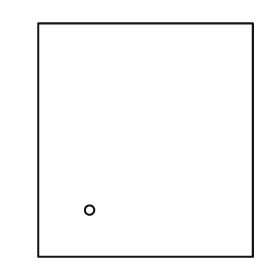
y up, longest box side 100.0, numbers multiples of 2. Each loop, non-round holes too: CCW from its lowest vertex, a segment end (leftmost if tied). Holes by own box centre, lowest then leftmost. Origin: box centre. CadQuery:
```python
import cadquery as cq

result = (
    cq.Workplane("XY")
    .moveTo(-46.0, -50.0)
    .lineTo(46.0, -50.0)
    .lineTo(46.0, 50.0)
    .lineTo(-46.0, 50.0)
    .close()
    .moveTo(-24.0, -30.0)
    .circle(2.0)
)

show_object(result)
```